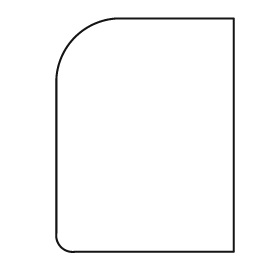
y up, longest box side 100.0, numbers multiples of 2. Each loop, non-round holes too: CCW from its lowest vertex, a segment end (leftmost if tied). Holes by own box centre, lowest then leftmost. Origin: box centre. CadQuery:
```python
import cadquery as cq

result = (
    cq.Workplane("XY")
    .moveTo(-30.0, -50.0)
    .lineTo(38.0, -50.0)
    .lineTo(38.0, 50.0)
    .lineTo(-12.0, 50.0)
    .threePointArc((-30.0, 42.0), (-38.0, 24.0))
    .lineTo(-38.0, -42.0)
    .threePointArc((-36.0, -48.0), (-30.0, -50.0))
    .close()
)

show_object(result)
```